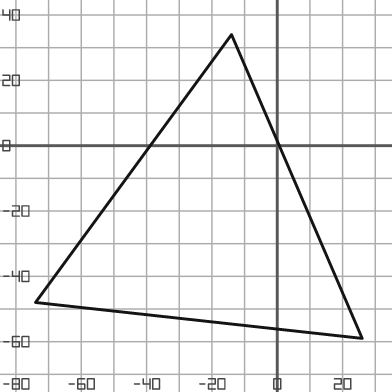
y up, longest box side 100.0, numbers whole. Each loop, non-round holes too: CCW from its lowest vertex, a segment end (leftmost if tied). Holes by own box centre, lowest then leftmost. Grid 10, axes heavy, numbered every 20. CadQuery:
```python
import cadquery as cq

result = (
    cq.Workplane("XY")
    .moveTo(26.0, -59.0)
    .lineTo(-14.0, 34.0)
    .lineTo(-74.0, -48.0)
    .close()
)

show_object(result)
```